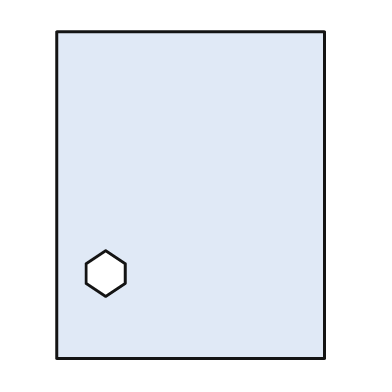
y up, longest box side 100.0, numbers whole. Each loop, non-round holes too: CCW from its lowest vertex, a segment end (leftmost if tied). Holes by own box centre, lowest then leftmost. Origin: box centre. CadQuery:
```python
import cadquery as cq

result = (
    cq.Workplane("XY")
    .moveTo(-41.0, -50.0)
    .lineTo(41.0, -50.0)
    .lineTo(41.0, 50.0)
    .lineTo(-41.0, 50.0)
    .close()
    .moveTo(-26.0, -31.0)
    .lineTo(-20.0, -27.0)
    .lineTo(-20.0, -21.0)
    .lineTo(-26.0, -17.0)
    .lineTo(-32.0, -21.0)
    .lineTo(-32.0, -27.0)
    .close()
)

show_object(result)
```